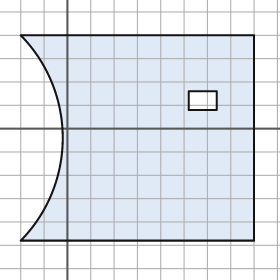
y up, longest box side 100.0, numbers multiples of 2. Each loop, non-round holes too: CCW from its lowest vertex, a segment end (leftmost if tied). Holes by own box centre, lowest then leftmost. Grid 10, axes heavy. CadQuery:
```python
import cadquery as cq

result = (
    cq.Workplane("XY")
    .moveTo(-20.0, -48.0)
    .lineTo(80.0, -48.0)
    .lineTo(80.0, 40.0)
    .lineTo(-20.0, 40.0)
    .threePointArc((-2.0, -4.0), (-20.0, -48.0))
    .close()
    .moveTo(52.0, 8.0)
    .lineTo(64.0, 8.0)
    .lineTo(64.0, 16.0)
    .lineTo(52.0, 16.0)
    .close()
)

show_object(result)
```